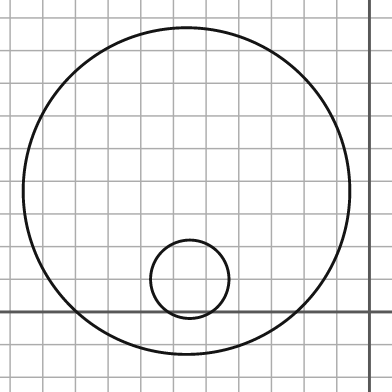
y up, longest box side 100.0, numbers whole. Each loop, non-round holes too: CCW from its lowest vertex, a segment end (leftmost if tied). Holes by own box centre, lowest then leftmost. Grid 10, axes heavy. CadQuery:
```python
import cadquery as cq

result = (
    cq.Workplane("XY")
    .moveTo(-56.0, 37.0)
    .circle(50.0)
    .moveTo(-55.0, 10.0)
    .circle(12.0)
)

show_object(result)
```